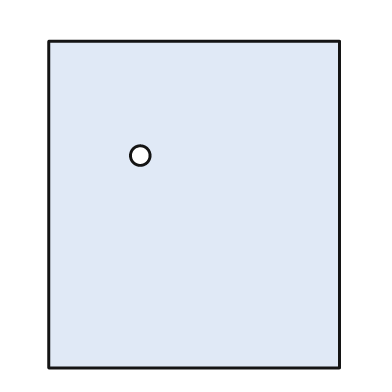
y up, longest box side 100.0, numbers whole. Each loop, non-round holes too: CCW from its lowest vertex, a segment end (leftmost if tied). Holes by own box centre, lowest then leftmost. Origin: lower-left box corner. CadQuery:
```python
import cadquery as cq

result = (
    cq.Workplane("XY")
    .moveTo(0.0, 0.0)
    .lineTo(89.0, 0.0)
    .lineTo(89.0, 100.0)
    .lineTo(0.0, 100.0)
    .close()
    .moveTo(28.0, 65.0)
    .circle(3.0)
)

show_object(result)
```